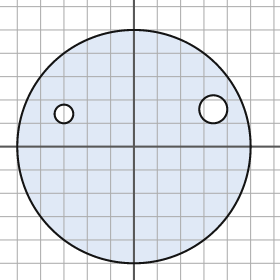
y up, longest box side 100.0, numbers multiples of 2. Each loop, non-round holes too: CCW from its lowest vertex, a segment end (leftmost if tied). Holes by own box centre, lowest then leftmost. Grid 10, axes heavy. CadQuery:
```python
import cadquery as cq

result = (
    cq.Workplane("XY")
    .moveTo(0.0, 0.0)
    .circle(50.0)
    .moveTo(-30.0, 14.0)
    .circle(4.0)
    .moveTo(34.0, 16.0)
    .circle(6.0)
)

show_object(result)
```